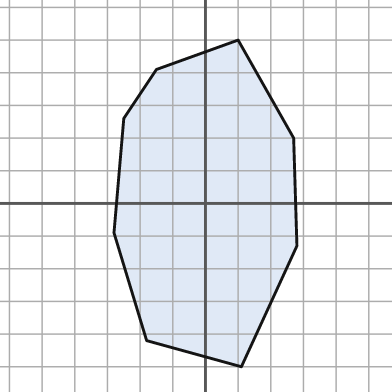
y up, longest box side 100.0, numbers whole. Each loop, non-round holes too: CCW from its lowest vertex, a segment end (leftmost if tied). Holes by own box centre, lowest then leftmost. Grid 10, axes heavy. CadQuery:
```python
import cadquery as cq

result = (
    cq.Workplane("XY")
    .moveTo(11.0, -50.0)
    .lineTo(28.0, -13.0)
    .lineTo(27.0, 20.0)
    .lineTo(10.0, 50.0)
    .lineTo(-15.0, 41.0)
    .lineTo(-25.0, 26.0)
    .lineTo(-28.0, -9.0)
    .lineTo(-18.0, -42.0)
    .close()
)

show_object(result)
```